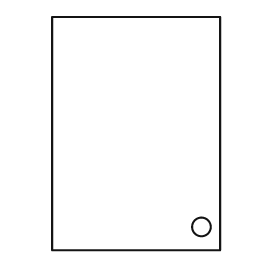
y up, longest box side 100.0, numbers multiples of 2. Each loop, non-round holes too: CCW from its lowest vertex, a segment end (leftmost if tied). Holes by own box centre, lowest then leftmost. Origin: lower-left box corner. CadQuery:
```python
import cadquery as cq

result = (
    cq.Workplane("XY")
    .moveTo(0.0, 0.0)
    .lineTo(72.0, 0.0)
    .lineTo(72.0, 100.0)
    .lineTo(0.0, 100.0)
    .close()
    .moveTo(64.0, 10.0)
    .circle(4.0)
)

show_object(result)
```